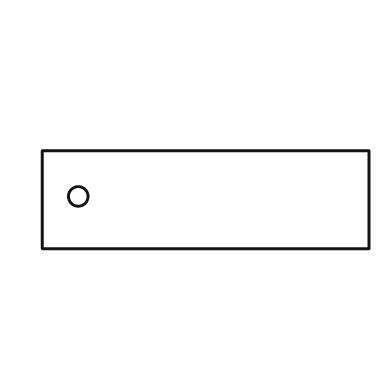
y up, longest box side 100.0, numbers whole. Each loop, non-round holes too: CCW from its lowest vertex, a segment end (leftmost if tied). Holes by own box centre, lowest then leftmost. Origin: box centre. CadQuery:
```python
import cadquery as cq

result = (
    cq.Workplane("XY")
    .moveTo(-50.0, -15.0)
    .lineTo(50.0, -15.0)
    .lineTo(50.0, 15.0)
    .lineTo(-50.0, 15.0)
    .close()
    .moveTo(-39.0, 1.0)
    .circle(3.0)
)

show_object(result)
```